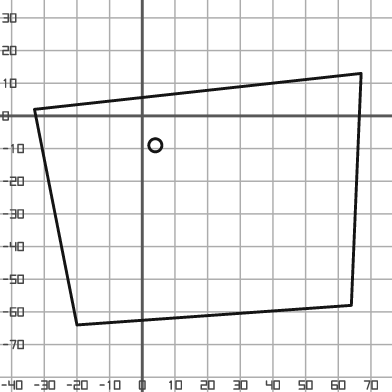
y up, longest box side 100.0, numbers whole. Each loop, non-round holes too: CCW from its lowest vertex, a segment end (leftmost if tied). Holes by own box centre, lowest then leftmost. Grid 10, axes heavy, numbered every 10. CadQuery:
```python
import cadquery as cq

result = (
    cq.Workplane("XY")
    .moveTo(-20.0, -64.0)
    .lineTo(64.0, -58.0)
    .lineTo(67.0, 13.0)
    .lineTo(-33.0, 2.0)
    .close()
    .moveTo(4.0, -9.0)
    .circle(2.0)
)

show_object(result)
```